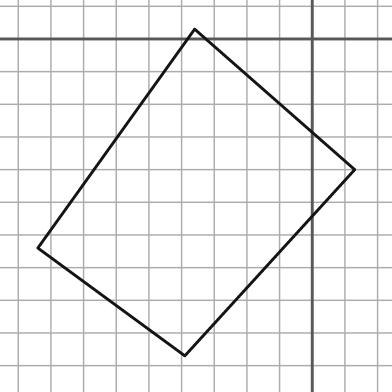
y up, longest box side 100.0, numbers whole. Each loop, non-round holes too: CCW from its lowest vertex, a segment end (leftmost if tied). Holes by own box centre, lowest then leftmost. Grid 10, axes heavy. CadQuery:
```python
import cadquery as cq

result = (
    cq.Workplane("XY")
    .moveTo(-39.0, -97.0)
    .lineTo(13.0, -40.0)
    .lineTo(-36.0, 3.0)
    .lineTo(-84.0, -64.0)
    .close()
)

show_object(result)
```